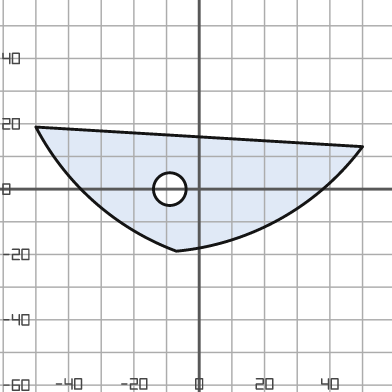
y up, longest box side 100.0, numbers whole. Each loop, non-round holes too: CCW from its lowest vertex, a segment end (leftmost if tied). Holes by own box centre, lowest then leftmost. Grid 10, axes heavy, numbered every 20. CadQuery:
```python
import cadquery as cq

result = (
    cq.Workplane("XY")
    .moveTo(-7.0, -19.0)
    .threePointArc((25.0, -9.0), (50.0, 13.0))
    .lineTo(-50.0, 19.0)
    .threePointArc((-32.0, -4.0), (-7.0, -19.0))
    .close()
    .moveTo(-9.0, 0.0)
    .circle(5.0)
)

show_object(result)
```